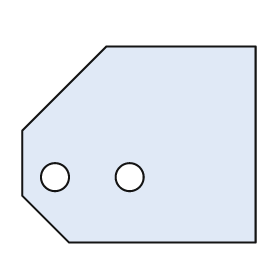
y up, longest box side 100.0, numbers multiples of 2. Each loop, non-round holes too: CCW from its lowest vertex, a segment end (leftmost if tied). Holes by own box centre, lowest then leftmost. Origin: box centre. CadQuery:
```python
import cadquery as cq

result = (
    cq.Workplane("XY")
    .moveTo(-30.0, -42.0)
    .lineTo(50.0, -42.0)
    .lineTo(50.0, 42.0)
    .lineTo(-14.0, 42.0)
    .lineTo(-50.0, 6.0)
    .lineTo(-50.0, -22.0)
    .close()
    .moveTo(-36.0, -14.0)
    .circle(6.0)
    .moveTo(-4.0, -14.0)
    .circle(6.0)
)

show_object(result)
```